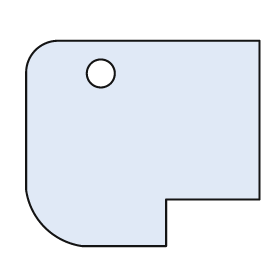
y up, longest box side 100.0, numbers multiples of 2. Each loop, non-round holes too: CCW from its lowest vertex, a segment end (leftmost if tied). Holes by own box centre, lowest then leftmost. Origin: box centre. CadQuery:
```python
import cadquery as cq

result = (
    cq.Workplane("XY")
    .moveTo(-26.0, -44.0)
    .lineTo(10.0, -44.0)
    .lineTo(10.0, -24.0)
    .lineTo(50.0, -24.0)
    .lineTo(50.0, 44.0)
    .lineTo(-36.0, 44.0)
    .threePointArc((-46.0, 40.0), (-50.0, 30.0))
    .lineTo(-50.0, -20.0)
    .threePointArc((-42.0, -36.0), (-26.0, -44.0))
    .close()
    .moveTo(-18.0, 30.0)
    .circle(6.0)
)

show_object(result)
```